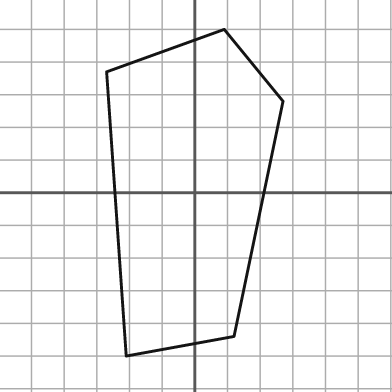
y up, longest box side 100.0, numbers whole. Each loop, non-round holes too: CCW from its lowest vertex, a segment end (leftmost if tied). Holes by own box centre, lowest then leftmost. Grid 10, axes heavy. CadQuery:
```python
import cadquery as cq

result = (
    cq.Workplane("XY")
    .moveTo(-21.0, -50.0)
    .lineTo(12.0, -44.0)
    .lineTo(27.0, 28.0)
    .lineTo(9.0, 50.0)
    .lineTo(-27.0, 37.0)
    .close()
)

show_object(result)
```